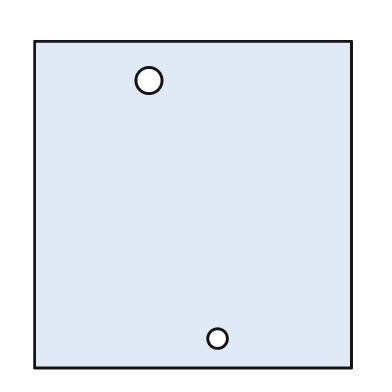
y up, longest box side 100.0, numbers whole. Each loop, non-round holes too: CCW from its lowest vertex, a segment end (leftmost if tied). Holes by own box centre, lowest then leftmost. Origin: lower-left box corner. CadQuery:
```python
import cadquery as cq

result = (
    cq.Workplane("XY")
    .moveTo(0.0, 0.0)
    .lineTo(97.0, 0.0)
    .lineTo(97.0, 100.0)
    .lineTo(0.0, 100.0)
    .close()
    .moveTo(56.0, 9.0)
    .circle(3.0)
    .moveTo(35.0, 88.0)
    .circle(4.0)
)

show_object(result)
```